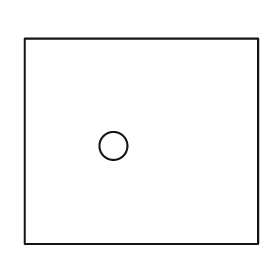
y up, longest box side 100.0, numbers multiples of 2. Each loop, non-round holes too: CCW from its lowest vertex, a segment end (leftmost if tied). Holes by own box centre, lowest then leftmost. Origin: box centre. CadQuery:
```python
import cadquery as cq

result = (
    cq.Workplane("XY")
    .moveTo(-50.0, -44.0)
    .lineTo(50.0, -44.0)
    .lineTo(50.0, 44.0)
    .lineTo(-50.0, 44.0)
    .close()
    .moveTo(-12.0, -2.0)
    .circle(6.0)
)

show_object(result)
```